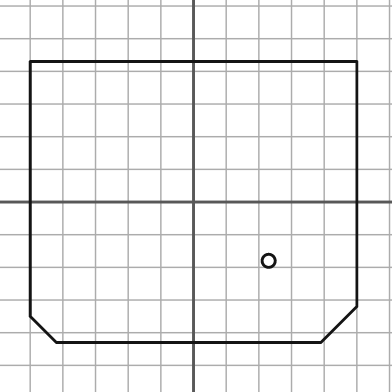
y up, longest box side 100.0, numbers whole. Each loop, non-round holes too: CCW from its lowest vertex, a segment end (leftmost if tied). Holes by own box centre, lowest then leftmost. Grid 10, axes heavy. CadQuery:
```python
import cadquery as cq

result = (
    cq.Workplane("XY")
    .moveTo(-42.0, -43.0)
    .lineTo(39.0, -43.0)
    .lineTo(50.0, -32.0)
    .lineTo(50.0, 43.0)
    .lineTo(-50.0, 43.0)
    .lineTo(-50.0, -35.0)
    .close()
    .moveTo(23.0, -18.0)
    .circle(2.0)
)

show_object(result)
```